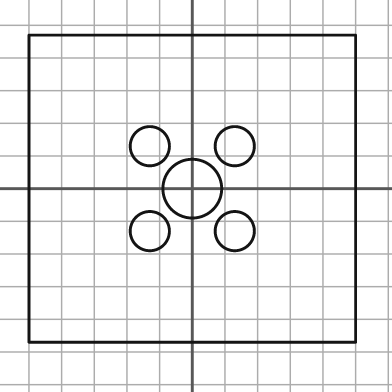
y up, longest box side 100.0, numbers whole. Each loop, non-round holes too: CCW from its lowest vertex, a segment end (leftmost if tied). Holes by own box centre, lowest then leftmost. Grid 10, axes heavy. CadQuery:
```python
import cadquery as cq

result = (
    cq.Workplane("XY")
    .moveTo(-50.0, -47.0)
    .lineTo(50.0, -47.0)
    .lineTo(50.0, 47.0)
    .lineTo(-50.0, 47.0)
    .close()
    .moveTo(-13.0, -13.0)
    .circle(6.0)
    .moveTo(13.0, -13.0)
    .circle(6.0)
    .moveTo(0.0, 0.0)
    .circle(9.0)
    .moveTo(-13.0, 13.0)
    .circle(6.0)
    .moveTo(13.0, 13.0)
    .circle(6.0)
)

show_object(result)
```